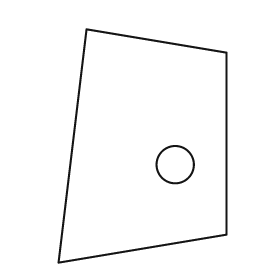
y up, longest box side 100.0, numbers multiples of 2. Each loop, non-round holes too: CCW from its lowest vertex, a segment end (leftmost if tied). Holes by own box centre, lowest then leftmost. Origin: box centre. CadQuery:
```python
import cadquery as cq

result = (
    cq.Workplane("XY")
    .moveTo(-36.0, -50.0)
    .lineTo(36.0, -38.0)
    .lineTo(36.0, 40.0)
    .lineTo(-24.0, 50.0)
    .close()
    .moveTo(14.0, -8.0)
    .circle(8.0)
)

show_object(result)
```